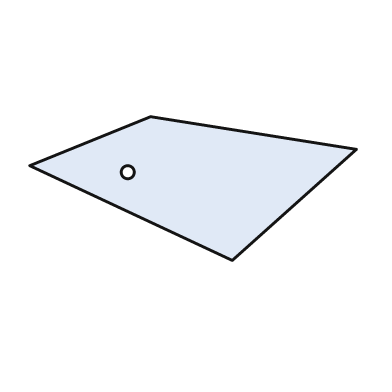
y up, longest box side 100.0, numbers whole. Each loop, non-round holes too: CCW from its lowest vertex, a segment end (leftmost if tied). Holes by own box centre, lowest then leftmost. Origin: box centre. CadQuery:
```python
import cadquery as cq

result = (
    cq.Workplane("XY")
    .moveTo(12.0, -22.0)
    .lineTo(50.0, 12.0)
    .lineTo(-13.0, 22.0)
    .lineTo(-50.0, 7.0)
    .close()
    .moveTo(-20.0, 5.0)
    .circle(2.0)
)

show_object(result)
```